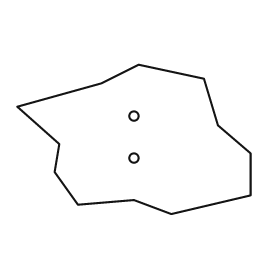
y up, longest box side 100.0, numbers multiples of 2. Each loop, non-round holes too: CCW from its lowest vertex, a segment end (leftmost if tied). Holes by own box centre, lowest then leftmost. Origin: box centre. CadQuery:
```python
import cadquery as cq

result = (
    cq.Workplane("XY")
    .moveTo(16.0, -32.0)
    .lineTo(50.0, -24.0)
    .lineTo(50.0, -6.0)
    .lineTo(36.0, 6.0)
    .lineTo(30.0, 26.0)
    .lineTo(2.0, 32.0)
    .lineTo(-14.0, 24.0)
    .lineTo(-50.0, 14.0)
    .lineTo(-32.0, -2.0)
    .lineTo(-34.0, -14.0)
    .lineTo(-24.0, -28.0)
    .lineTo(0.0, -26.0)
    .close()
    .moveTo(0.0, -8.0)
    .circle(2.0)
    .moveTo(0.0, 10.0)
    .circle(2.0)
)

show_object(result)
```